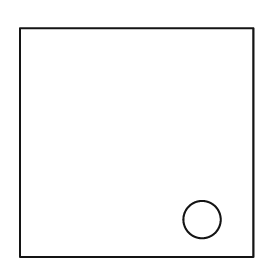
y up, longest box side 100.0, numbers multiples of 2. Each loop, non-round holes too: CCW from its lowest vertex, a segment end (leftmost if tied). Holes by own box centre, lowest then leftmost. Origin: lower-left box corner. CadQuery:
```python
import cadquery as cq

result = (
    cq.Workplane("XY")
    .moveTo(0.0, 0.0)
    .lineTo(100.0, 0.0)
    .lineTo(100.0, 98.0)
    .lineTo(0.0, 98.0)
    .close()
    .moveTo(78.0, 16.0)
    .circle(8.0)
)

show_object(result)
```